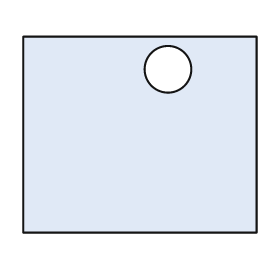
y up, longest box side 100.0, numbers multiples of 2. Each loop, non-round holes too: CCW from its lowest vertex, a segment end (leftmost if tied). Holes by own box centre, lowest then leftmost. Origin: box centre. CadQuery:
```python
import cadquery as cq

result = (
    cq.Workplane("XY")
    .moveTo(-50.0, -42.0)
    .lineTo(50.0, -42.0)
    .lineTo(50.0, 42.0)
    .lineTo(-50.0, 42.0)
    .close()
    .moveTo(12.0, 28.0)
    .circle(10.0)
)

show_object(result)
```